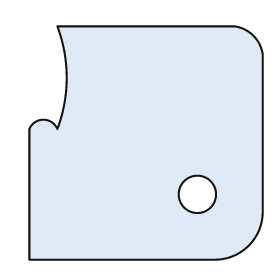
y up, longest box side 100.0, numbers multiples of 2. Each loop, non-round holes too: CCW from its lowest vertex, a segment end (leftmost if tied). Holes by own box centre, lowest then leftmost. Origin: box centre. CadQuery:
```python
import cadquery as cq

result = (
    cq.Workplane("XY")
    .moveTo(-50.0, -50.0)
    .lineTo(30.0, -50.0)
    .threePointArc((44.0, -44.0), (50.0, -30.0))
    .lineTo(50.0, 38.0)
    .threePointArc((46.0, 46.0), (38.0, 50.0))
    .lineTo(-38.0, 50.0)
    .threePointArc((-34.0, 28.0), (-38.0, 6.0))
    .threePointArc((-44.0, 10.0), (-50.0, 6.0))
    .close()
    .moveTo(22.0, -22.0)
    .circle(8.0)
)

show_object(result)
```